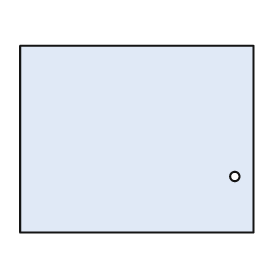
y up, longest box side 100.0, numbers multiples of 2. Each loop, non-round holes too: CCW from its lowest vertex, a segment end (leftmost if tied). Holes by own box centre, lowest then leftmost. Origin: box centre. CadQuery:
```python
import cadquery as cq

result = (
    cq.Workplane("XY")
    .moveTo(-50.0, -40.0)
    .lineTo(50.0, -40.0)
    .lineTo(50.0, 40.0)
    .lineTo(-50.0, 40.0)
    .close()
    .moveTo(42.0, -16.0)
    .circle(2.0)
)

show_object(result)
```